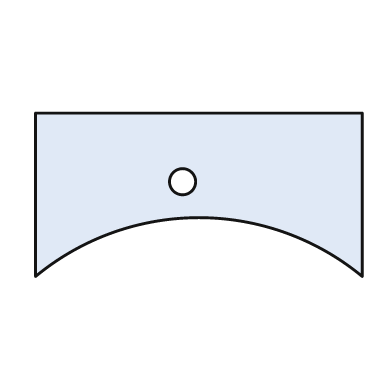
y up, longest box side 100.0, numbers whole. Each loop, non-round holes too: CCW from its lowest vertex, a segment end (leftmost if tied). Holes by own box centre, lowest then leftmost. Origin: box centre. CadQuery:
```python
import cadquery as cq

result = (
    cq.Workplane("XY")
    .moveTo(-50.0, -25.0)
    .threePointArc((0.0, -7.0), (50.0, -25.0))
    .lineTo(50.0, 25.0)
    .lineTo(-50.0, 25.0)
    .close()
    .moveTo(-5.0, 4.0)
    .circle(4.0)
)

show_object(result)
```